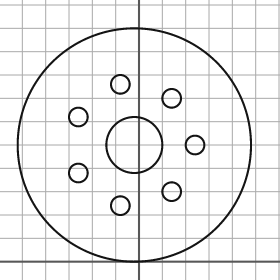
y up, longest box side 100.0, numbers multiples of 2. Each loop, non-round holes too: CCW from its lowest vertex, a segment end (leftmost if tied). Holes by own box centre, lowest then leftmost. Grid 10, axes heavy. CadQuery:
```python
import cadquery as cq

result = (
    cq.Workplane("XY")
    .moveTo(-2.0, 50.0)
    .circle(50.0)
    .moveTo(-8.0, 24.0)
    .circle(4.0)
    .moveTo(14.0, 30.0)
    .circle(4.0)
    .moveTo(-26.0, 38.0)
    .circle(4.0)
    .moveTo(-2.0, 50.0)
    .circle(12.0)
    .moveTo(24.0, 50.0)
    .circle(4.0)
    .moveTo(-26.0, 62.0)
    .circle(4.0)
    .moveTo(14.0, 70.0)
    .circle(4.0)
    .moveTo(-8.0, 76.0)
    .circle(4.0)
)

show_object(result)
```